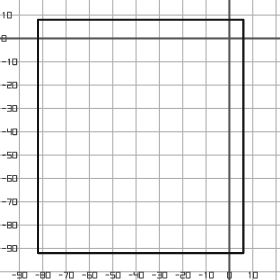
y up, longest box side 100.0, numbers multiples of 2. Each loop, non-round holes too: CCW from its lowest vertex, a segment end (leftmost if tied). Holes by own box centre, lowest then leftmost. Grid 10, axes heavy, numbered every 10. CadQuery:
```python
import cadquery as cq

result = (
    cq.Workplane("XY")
    .moveTo(-82.0, -92.0)
    .lineTo(6.0, -92.0)
    .lineTo(6.0, 8.0)
    .lineTo(-82.0, 8.0)
    .close()
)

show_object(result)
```